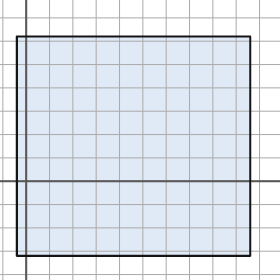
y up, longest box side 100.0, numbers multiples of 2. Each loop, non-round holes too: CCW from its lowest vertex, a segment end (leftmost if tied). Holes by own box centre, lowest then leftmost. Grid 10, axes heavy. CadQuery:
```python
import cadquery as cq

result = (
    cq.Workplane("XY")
    .moveTo(-4.0, -32.0)
    .lineTo(96.0, -32.0)
    .lineTo(96.0, 62.0)
    .lineTo(-4.0, 62.0)
    .close()
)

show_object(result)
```